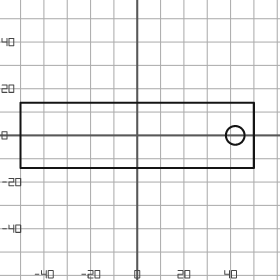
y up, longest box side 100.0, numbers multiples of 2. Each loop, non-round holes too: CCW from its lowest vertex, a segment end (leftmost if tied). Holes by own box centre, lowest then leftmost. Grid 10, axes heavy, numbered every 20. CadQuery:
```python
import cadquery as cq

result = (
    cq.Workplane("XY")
    .moveTo(-50.0, -14.0)
    .lineTo(50.0, -14.0)
    .lineTo(50.0, 14.0)
    .lineTo(-50.0, 14.0)
    .close()
    .moveTo(42.0, 0.0)
    .circle(4.0)
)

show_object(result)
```